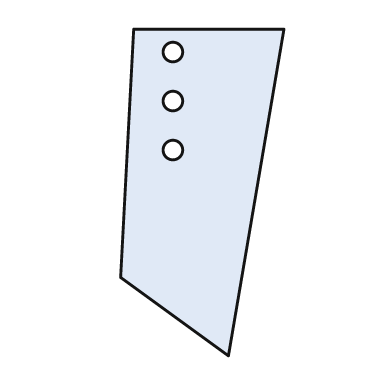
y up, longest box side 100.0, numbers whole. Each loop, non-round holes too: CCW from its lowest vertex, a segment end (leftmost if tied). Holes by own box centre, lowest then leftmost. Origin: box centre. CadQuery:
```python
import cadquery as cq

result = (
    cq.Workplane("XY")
    .moveTo(8.0, -50.0)
    .lineTo(25.0, 50.0)
    .lineTo(-21.0, 50.0)
    .lineTo(-25.0, -26.0)
    .close()
    .moveTo(-9.0, 13.0)
    .circle(3.0)
    .moveTo(-9.0, 28.0)
    .circle(3.0)
    .moveTo(-9.0, 43.0)
    .circle(3.0)
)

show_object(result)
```